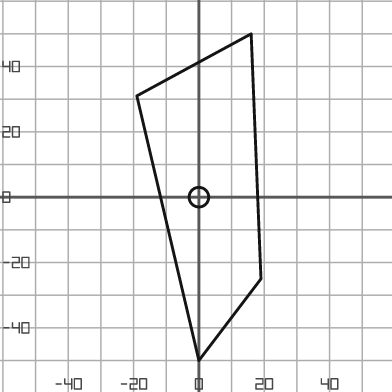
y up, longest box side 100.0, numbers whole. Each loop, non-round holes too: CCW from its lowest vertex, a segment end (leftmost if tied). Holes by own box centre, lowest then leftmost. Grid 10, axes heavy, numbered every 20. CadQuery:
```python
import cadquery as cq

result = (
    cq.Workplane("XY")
    .moveTo(0.0, -50.0)
    .lineTo(19.0, -25.0)
    .lineTo(16.0, 50.0)
    .lineTo(-19.0, 31.0)
    .close()
    .moveTo(0.0, 0.0)
    .circle(3.0)
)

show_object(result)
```